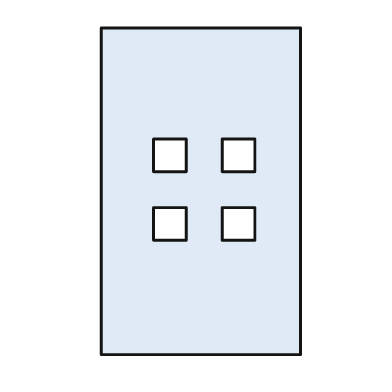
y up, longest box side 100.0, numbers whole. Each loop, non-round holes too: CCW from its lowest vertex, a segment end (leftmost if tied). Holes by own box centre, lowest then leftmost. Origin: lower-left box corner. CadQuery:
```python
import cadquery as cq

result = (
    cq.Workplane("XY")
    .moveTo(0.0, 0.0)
    .lineTo(61.0, 0.0)
    .lineTo(61.0, 100.0)
    .lineTo(0.0, 100.0)
    .close()
    .moveTo(16.0, 35.0)
    .lineTo(26.0, 35.0)
    .lineTo(26.0, 45.0)
    .lineTo(16.0, 45.0)
    .close()
    .moveTo(37.0, 35.0)
    .lineTo(47.0, 35.0)
    .lineTo(47.0, 45.0)
    .lineTo(37.0, 45.0)
    .close()
    .moveTo(16.0, 56.0)
    .lineTo(26.0, 56.0)
    .lineTo(26.0, 66.0)
    .lineTo(16.0, 66.0)
    .close()
    .moveTo(37.0, 56.0)
    .lineTo(47.0, 56.0)
    .lineTo(47.0, 66.0)
    .lineTo(37.0, 66.0)
    .close()
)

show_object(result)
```